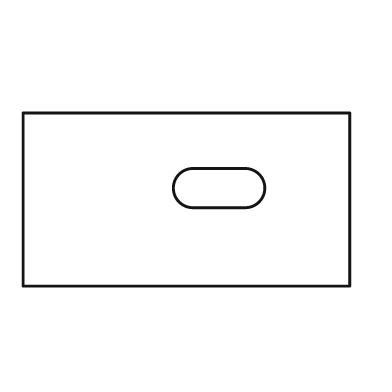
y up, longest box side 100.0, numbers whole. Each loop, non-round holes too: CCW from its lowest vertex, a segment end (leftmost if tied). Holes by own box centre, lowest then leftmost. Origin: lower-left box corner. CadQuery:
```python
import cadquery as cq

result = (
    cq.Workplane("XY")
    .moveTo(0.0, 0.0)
    .lineTo(100.0, 0.0)
    .lineTo(100.0, 53.0)
    .lineTo(0.0, 53.0)
    .close()
    .moveTo(52.0, 24.0)
    .lineTo(68.0, 24.0)
    .threePointArc((74.0, 30.0), (68.0, 36.0))
    .lineTo(52.0, 36.0)
    .threePointArc((46.0, 30.0), (52.0, 24.0))
    .close()
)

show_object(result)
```